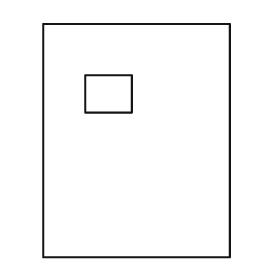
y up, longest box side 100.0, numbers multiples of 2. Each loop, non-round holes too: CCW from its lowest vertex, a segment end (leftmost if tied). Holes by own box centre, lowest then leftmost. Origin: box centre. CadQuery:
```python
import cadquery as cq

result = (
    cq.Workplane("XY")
    .moveTo(-40.0, -50.0)
    .lineTo(40.0, -50.0)
    .lineTo(40.0, 50.0)
    .lineTo(-40.0, 50.0)
    .close()
    .moveTo(-22.0, 12.0)
    .lineTo(-2.0, 12.0)
    .lineTo(-2.0, 28.0)
    .lineTo(-22.0, 28.0)
    .close()
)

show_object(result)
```